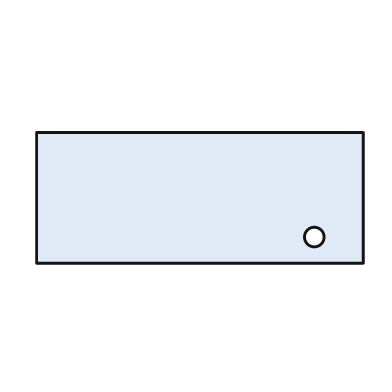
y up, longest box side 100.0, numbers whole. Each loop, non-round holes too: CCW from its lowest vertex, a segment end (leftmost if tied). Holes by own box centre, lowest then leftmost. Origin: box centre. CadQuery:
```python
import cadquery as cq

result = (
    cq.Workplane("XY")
    .moveTo(-50.0, -20.0)
    .lineTo(50.0, -20.0)
    .lineTo(50.0, 20.0)
    .lineTo(-50.0, 20.0)
    .close()
    .moveTo(35.0, -12.0)
    .circle(3.0)
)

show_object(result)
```